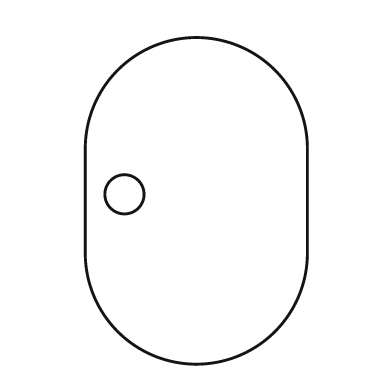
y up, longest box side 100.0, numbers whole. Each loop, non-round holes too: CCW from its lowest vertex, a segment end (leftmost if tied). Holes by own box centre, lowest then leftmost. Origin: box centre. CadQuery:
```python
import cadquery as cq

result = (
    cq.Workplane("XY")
    .moveTo(-34.0, -16.0)
    .threePointArc((0.0, -50.0), (34.0, -16.0))
    .lineTo(34.0, 16.0)
    .threePointArc((0.0, 50.0), (-34.0, 16.0))
    .close()
    .moveTo(-22.0, 2.0)
    .circle(6.0)
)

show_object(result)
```